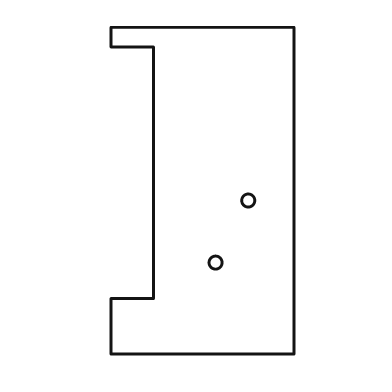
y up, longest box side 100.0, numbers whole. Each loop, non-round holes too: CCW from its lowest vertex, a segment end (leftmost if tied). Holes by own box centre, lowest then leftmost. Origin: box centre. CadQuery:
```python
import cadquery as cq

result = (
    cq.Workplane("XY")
    .moveTo(-28.0, -50.0)
    .lineTo(28.0, -50.0)
    .lineTo(28.0, 50.0)
    .lineTo(-28.0, 50.0)
    .lineTo(-28.0, 44.0)
    .lineTo(-15.0, 44.0)
    .lineTo(-15.0, -33.0)
    .lineTo(-28.0, -33.0)
    .close()
    .moveTo(4.0, -22.0)
    .circle(2.0)
    .moveTo(14.0, -3.0)
    .circle(2.0)
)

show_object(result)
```